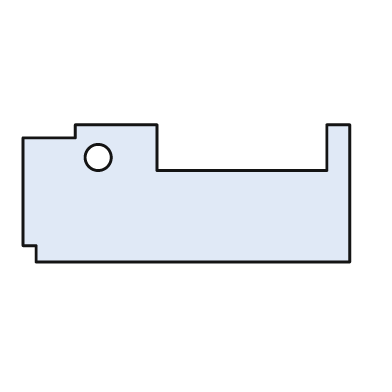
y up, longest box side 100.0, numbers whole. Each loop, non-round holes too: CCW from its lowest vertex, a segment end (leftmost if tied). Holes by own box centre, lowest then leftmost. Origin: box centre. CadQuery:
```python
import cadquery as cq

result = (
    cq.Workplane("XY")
    .moveTo(-46.0, -21.0)
    .lineTo(50.0, -21.0)
    .lineTo(50.0, 21.0)
    .lineTo(43.0, 21.0)
    .lineTo(43.0, 7.0)
    .lineTo(-9.0, 7.0)
    .lineTo(-9.0, 21.0)
    .lineTo(-34.0, 21.0)
    .lineTo(-34.0, 17.0)
    .lineTo(-50.0, 17.0)
    .lineTo(-50.0, -16.0)
    .lineTo(-46.0, -16.0)
    .close()
    .moveTo(-27.0, 11.0)
    .circle(4.0)
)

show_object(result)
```